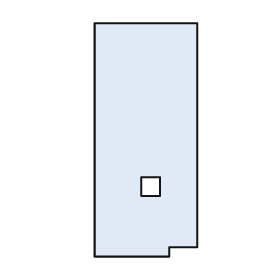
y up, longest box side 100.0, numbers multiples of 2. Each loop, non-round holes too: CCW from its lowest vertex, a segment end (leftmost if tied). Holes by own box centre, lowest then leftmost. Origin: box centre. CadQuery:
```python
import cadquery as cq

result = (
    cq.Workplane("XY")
    .moveTo(-22.0, -50.0)
    .lineTo(10.0, -50.0)
    .lineTo(10.0, -46.0)
    .lineTo(22.0, -46.0)
    .lineTo(22.0, 50.0)
    .lineTo(-22.0, 50.0)
    .close()
    .moveTo(-2.0, -24.0)
    .lineTo(6.0, -24.0)
    .lineTo(6.0, -16.0)
    .lineTo(-2.0, -16.0)
    .close()
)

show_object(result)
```